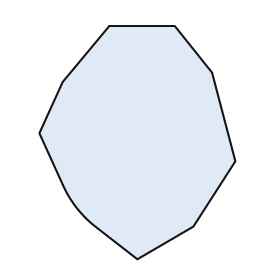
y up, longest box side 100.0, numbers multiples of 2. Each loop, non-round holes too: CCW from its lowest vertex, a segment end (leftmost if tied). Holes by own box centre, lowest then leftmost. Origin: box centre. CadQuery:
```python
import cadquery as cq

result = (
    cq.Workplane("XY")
    .moveTo(0.0, -50.0)
    .lineTo(24.0, -36.0)
    .lineTo(42.0, -8.0)
    .lineTo(32.0, 30.0)
    .lineTo(16.0, 50.0)
    .lineTo(-12.0, 50.0)
    .lineTo(-32.0, 26.0)
    .lineTo(-42.0, 4.0)
    .lineTo(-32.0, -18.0)
    .threePointArc((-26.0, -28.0), (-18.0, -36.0))
    .close()
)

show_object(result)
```